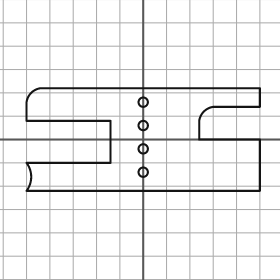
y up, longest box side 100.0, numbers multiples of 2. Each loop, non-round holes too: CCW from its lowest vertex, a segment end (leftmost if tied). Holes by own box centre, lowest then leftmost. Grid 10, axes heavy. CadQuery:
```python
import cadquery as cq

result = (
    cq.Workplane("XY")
    .moveTo(-50.0, -22.0)
    .lineTo(50.0, -22.0)
    .lineTo(50.0, 0.0)
    .lineTo(24.0, 0.0)
    .lineTo(24.0, 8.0)
    .threePointArc((26.0, 12.0), (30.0, 14.0))
    .lineTo(50.0, 14.0)
    .lineTo(50.0, 22.0)
    .lineTo(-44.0, 22.0)
    .threePointArc((-48.0, 20.0), (-50.0, 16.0))
    .lineTo(-50.0, 8.0)
    .lineTo(-14.0, 8.0)
    .lineTo(-14.0, -10.0)
    .lineTo(-50.0, -10.0)
    .threePointArc((-48.0, -16.0), (-50.0, -22.0))
    .close()
    .moveTo(0.0, -14.0)
    .circle(2.0)
    .moveTo(0.0, -4.0)
    .circle(2.0)
    .moveTo(0.0, 6.0)
    .circle(2.0)
    .moveTo(0.0, 16.0)
    .circle(2.0)
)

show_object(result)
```